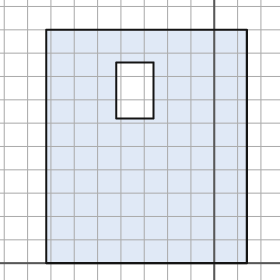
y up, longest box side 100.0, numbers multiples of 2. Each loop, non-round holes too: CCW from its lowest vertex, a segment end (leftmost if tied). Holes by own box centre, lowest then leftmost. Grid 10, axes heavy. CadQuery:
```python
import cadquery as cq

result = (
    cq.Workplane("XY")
    .moveTo(-72.0, 0.0)
    .lineTo(14.0, 0.0)
    .lineTo(14.0, 100.0)
    .lineTo(-72.0, 100.0)
    .close()
    .moveTo(-42.0, 62.0)
    .lineTo(-26.0, 62.0)
    .lineTo(-26.0, 86.0)
    .lineTo(-42.0, 86.0)
    .close()
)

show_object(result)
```